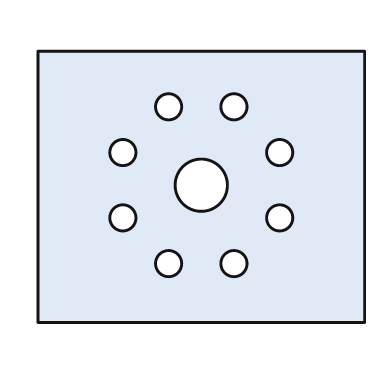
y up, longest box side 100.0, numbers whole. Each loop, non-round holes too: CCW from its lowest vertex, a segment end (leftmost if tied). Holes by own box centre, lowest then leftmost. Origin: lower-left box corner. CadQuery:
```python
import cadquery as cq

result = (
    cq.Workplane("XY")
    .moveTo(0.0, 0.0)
    .lineTo(100.0, 0.0)
    .lineTo(100.0, 83.0)
    .lineTo(0.0, 83.0)
    .close()
    .moveTo(40.0, 18.0)
    .circle(4.0)
    .moveTo(60.0, 18.0)
    .circle(4.0)
    .moveTo(26.0, 32.0)
    .circle(4.0)
    .moveTo(74.0, 32.0)
    .circle(4.0)
    .moveTo(50.0, 42.0)
    .circle(8.0)
    .moveTo(26.0, 52.0)
    .circle(4.0)
    .moveTo(74.0, 52.0)
    .circle(4.0)
    .moveTo(40.0, 66.0)
    .circle(4.0)
    .moveTo(60.0, 66.0)
    .circle(4.0)
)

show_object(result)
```